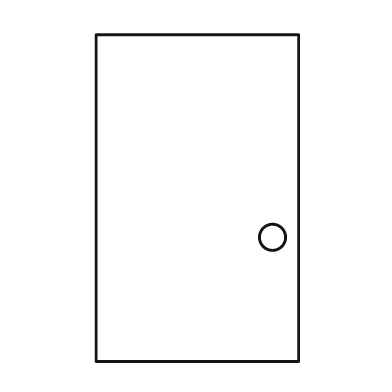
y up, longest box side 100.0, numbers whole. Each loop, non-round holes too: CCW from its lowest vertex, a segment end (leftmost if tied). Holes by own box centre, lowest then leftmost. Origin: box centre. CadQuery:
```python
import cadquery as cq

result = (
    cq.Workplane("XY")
    .moveTo(-31.0, -50.0)
    .lineTo(31.0, -50.0)
    .lineTo(31.0, 50.0)
    .lineTo(-31.0, 50.0)
    .close()
    .moveTo(23.0, -12.0)
    .circle(4.0)
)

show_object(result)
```